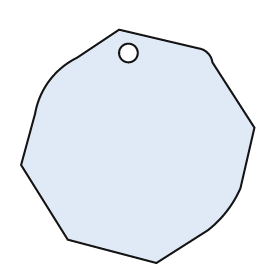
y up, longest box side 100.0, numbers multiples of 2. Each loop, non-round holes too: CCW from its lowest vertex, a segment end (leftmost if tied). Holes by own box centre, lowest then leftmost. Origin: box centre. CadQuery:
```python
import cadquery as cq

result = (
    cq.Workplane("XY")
    .moveTo(8.0, -50.0)
    .lineTo(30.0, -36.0)
    .threePointArc((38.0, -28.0), (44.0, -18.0))
    .lineTo(50.0, 8.0)
    .lineTo(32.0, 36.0)
    .threePointArc((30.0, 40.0), (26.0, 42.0))
    .lineTo(-8.0, 50.0)
    .lineTo(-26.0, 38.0)
    .threePointArc((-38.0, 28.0), (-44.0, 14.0))
    .lineTo(-50.0, -8.0)
    .lineTo(-30.0, -40.0)
    .close()
    .moveTo(-4.0, 40.0)
    .circle(4.0)
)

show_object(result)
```